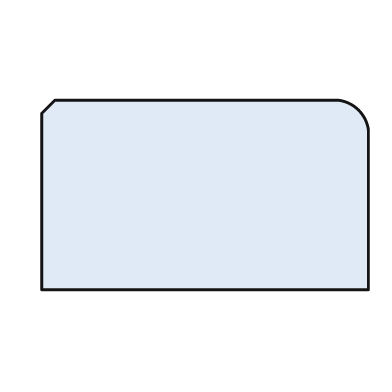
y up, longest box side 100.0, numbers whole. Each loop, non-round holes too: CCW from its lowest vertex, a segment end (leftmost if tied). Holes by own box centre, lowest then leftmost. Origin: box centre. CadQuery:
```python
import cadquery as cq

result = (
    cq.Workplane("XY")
    .moveTo(-50.0, -29.0)
    .lineTo(50.0, -29.0)
    .lineTo(50.0, 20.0)
    .threePointArc((47.0, 26.0), (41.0, 29.0))
    .lineTo(-46.0, 29.0)
    .lineTo(-50.0, 25.0)
    .close()
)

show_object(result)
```